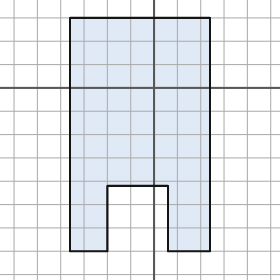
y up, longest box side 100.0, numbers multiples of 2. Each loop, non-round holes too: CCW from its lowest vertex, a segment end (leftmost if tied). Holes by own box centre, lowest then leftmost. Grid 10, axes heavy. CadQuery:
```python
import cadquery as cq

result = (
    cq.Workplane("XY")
    .moveTo(-36.0, -70.0)
    .lineTo(-20.0, -70.0)
    .lineTo(-20.0, -42.0)
    .lineTo(6.0, -42.0)
    .lineTo(6.0, -70.0)
    .lineTo(24.0, -70.0)
    .lineTo(24.0, 30.0)
    .lineTo(-36.0, 30.0)
    .close()
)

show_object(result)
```